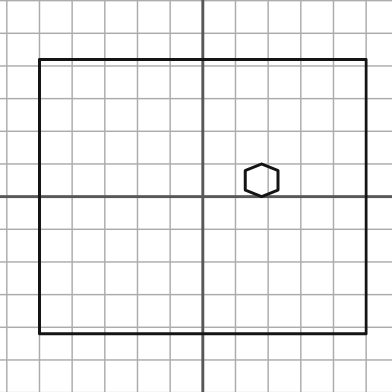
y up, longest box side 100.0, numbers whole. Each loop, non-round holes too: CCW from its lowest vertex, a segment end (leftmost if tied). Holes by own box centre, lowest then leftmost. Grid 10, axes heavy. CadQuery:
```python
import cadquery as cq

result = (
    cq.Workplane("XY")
    .moveTo(-50.0, -42.0)
    .lineTo(50.0, -42.0)
    .lineTo(50.0, 42.0)
    .lineTo(-50.0, 42.0)
    .close()
    .moveTo(18.0, 0.0)
    .lineTo(23.0, 2.0)
    .lineTo(23.0, 8.0)
    .lineTo(18.0, 10.0)
    .lineTo(13.0, 8.0)
    .lineTo(13.0, 2.0)
    .close()
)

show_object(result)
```